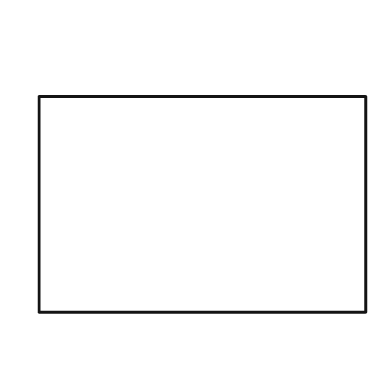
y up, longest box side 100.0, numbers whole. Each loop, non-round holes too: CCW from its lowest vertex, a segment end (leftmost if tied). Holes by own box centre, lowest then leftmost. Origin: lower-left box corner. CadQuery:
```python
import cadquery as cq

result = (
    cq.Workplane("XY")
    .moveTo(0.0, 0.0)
    .lineTo(100.0, 0.0)
    .lineTo(100.0, 66.0)
    .lineTo(0.0, 66.0)
    .close()
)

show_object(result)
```